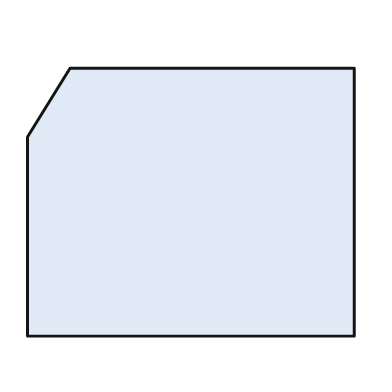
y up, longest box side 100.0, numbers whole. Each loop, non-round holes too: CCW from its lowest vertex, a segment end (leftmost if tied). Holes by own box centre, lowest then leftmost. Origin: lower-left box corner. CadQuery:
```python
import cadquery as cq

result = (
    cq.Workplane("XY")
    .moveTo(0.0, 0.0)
    .lineTo(100.0, 0.0)
    .lineTo(100.0, 82.0)
    .lineTo(13.0, 82.0)
    .lineTo(0.0, 61.0)
    .close()
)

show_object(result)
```